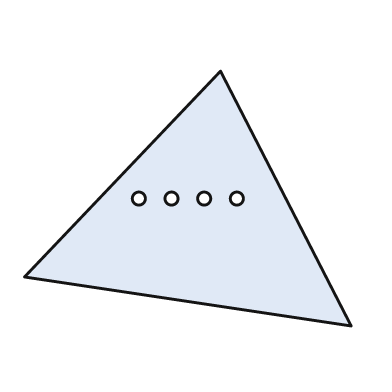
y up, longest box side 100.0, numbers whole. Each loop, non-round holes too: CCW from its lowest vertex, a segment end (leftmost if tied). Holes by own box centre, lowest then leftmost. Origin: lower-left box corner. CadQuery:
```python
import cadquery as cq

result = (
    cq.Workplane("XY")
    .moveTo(100.0, 0.0)
    .lineTo(60.0, 78.0)
    .lineTo(0.0, 15.0)
    .close()
    .moveTo(35.0, 39.0)
    .circle(2.0)
    .moveTo(45.0, 39.0)
    .circle(2.0)
    .moveTo(55.0, 39.0)
    .circle(2.0)
    .moveTo(65.0, 39.0)
    .circle(2.0)
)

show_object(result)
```